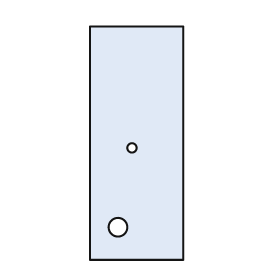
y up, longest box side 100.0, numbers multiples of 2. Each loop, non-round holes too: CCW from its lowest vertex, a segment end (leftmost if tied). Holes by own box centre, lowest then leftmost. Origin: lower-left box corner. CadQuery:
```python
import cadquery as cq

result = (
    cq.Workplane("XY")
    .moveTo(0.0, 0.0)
    .lineTo(40.0, 0.0)
    .lineTo(40.0, 100.0)
    .lineTo(0.0, 100.0)
    .close()
    .moveTo(12.0, 14.0)
    .circle(4.0)
    .moveTo(18.0, 48.0)
    .circle(2.0)
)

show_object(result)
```